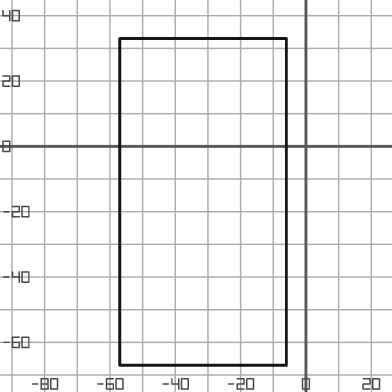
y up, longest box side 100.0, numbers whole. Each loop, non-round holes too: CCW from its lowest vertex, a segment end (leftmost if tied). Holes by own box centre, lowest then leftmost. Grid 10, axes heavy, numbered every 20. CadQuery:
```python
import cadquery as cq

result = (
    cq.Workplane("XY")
    .moveTo(-57.0, -67.0)
    .lineTo(-6.0, -67.0)
    .lineTo(-6.0, 33.0)
    .lineTo(-57.0, 33.0)
    .close()
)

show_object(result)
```